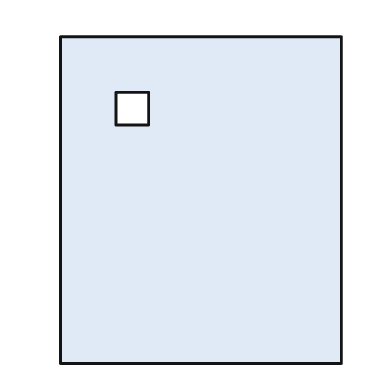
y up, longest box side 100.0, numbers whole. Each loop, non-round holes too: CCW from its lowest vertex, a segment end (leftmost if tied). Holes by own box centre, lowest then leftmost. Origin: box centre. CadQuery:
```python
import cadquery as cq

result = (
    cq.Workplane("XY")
    .moveTo(-43.0, -50.0)
    .lineTo(43.0, -50.0)
    .lineTo(43.0, 50.0)
    .lineTo(-43.0, 50.0)
    .close()
    .moveTo(-26.0, 23.0)
    .lineTo(-16.0, 23.0)
    .lineTo(-16.0, 33.0)
    .lineTo(-26.0, 33.0)
    .close()
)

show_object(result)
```